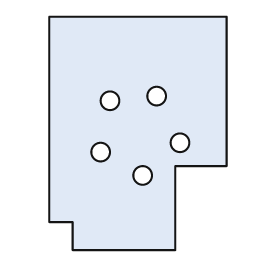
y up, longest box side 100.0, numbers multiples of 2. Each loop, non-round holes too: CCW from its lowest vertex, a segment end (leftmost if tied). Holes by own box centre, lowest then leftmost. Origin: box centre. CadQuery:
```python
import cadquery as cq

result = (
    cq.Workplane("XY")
    .moveTo(-28.0, -50.0)
    .lineTo(16.0, -50.0)
    .lineTo(16.0, -14.0)
    .lineTo(38.0, -14.0)
    .lineTo(38.0, 50.0)
    .lineTo(-38.0, 50.0)
    .lineTo(-38.0, -38.0)
    .lineTo(-28.0, -38.0)
    .close()
    .moveTo(2.0, -18.0)
    .circle(4.0)
    .moveTo(-16.0, -8.0)
    .circle(4.0)
    .moveTo(18.0, -4.0)
    .circle(4.0)
    .moveTo(-12.0, 14.0)
    .circle(4.0)
    .moveTo(8.0, 16.0)
    .circle(4.0)
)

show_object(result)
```